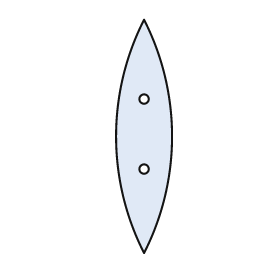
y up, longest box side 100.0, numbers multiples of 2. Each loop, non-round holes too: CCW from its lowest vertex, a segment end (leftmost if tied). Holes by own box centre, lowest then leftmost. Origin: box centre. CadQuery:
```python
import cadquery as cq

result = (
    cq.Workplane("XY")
    .moveTo(0.0, -50.0)
    .threePointArc((12.0, 0.0), (0.0, 50.0))
    .threePointArc((-12.0, 0.0), (0.0, -50.0))
    .close()
    .moveTo(0.0, -14.0)
    .circle(2.0)
    .moveTo(0.0, 16.0)
    .circle(2.0)
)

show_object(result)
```